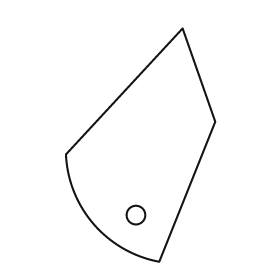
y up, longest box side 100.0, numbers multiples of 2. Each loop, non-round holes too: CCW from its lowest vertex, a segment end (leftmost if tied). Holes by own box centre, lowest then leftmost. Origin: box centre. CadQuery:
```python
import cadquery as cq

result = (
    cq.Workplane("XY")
    .moveTo(8.0, -50.0)
    .lineTo(32.0, 10.0)
    .lineTo(18.0, 50.0)
    .lineTo(-32.0, -4.0)
    .threePointArc((-20.0, -34.0), (8.0, -50.0))
    .close()
    .moveTo(-2.0, -30.0)
    .circle(4.0)
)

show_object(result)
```